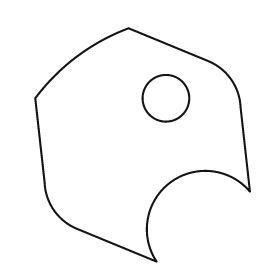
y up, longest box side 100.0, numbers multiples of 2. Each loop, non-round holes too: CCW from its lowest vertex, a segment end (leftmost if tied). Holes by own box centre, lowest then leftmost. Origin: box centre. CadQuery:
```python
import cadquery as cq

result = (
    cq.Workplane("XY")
    .moveTo(6.0, -50.0)
    .threePointArc((12.0, -16.0), (46.0, -20.0))
    .lineTo(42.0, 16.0)
    .threePointArc((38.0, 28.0), (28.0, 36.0))
    .lineTo(-6.0, 50.0)
    .threePointArc((-28.0, 38.0), (-46.0, 20.0))
    .lineTo(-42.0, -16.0)
    .threePointArc((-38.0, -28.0), (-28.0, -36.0))
    .close()
    .moveTo(10.0, 20.0)
    .circle(10.0)
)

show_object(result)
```